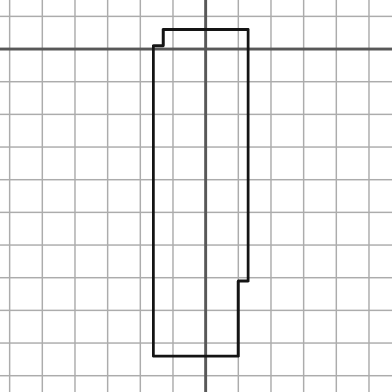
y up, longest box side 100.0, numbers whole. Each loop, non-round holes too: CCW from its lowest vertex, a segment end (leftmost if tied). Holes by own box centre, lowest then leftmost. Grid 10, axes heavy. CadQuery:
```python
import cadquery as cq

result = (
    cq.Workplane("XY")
    .moveTo(-16.0, -94.0)
    .lineTo(10.0, -94.0)
    .lineTo(10.0, -71.0)
    .lineTo(13.0, -71.0)
    .lineTo(13.0, 6.0)
    .lineTo(-13.0, 6.0)
    .lineTo(-13.0, 1.0)
    .lineTo(-16.0, 1.0)
    .close()
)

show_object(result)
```